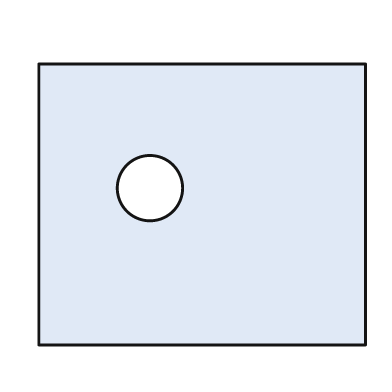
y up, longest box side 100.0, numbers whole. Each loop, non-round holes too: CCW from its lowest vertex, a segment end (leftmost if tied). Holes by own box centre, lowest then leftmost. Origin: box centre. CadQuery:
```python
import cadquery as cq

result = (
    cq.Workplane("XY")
    .moveTo(-50.0, -43.0)
    .lineTo(50.0, -43.0)
    .lineTo(50.0, 43.0)
    .lineTo(-50.0, 43.0)
    .close()
    .moveTo(-16.0, 5.0)
    .circle(10.0)
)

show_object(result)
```